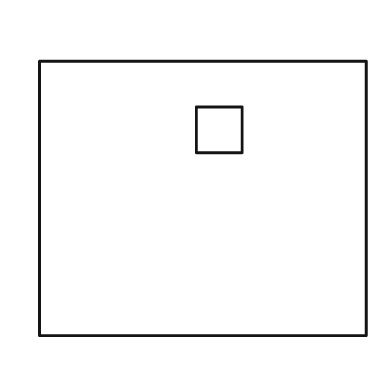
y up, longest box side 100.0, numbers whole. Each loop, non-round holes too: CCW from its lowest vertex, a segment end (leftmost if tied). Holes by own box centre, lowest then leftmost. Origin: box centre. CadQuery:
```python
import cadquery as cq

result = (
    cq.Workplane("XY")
    .moveTo(-50.0, -42.0)
    .lineTo(50.0, -42.0)
    .lineTo(50.0, 42.0)
    .lineTo(-50.0, 42.0)
    .close()
    .moveTo(-2.0, 14.0)
    .lineTo(12.0, 14.0)
    .lineTo(12.0, 28.0)
    .lineTo(-2.0, 28.0)
    .close()
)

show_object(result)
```